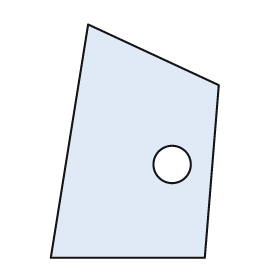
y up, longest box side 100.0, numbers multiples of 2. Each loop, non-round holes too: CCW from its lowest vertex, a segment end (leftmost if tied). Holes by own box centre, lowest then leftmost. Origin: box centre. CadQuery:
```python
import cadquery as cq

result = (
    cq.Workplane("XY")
    .moveTo(-36.0, -50.0)
    .lineTo(30.0, -50.0)
    .lineTo(36.0, 24.0)
    .lineTo(-20.0, 50.0)
    .close()
    .moveTo(16.0, -10.0)
    .circle(8.0)
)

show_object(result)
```